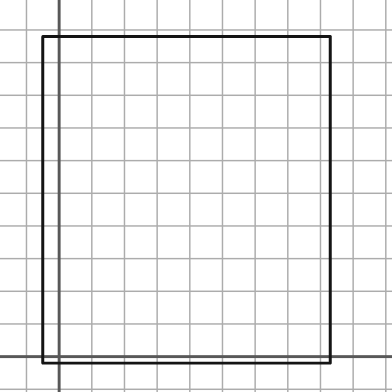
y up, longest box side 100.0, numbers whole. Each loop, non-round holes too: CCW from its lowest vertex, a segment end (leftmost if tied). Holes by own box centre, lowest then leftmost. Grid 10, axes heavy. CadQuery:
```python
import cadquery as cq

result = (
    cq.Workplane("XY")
    .moveTo(-5.0, -2.0)
    .lineTo(83.0, -2.0)
    .lineTo(83.0, 98.0)
    .lineTo(-5.0, 98.0)
    .close()
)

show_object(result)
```